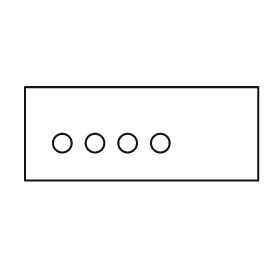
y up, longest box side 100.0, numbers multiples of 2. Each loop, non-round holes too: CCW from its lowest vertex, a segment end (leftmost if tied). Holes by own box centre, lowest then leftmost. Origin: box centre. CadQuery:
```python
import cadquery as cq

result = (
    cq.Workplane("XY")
    .moveTo(-50.0, -20.0)
    .lineTo(50.0, -20.0)
    .lineTo(50.0, 20.0)
    .lineTo(-50.0, 20.0)
    .close()
    .moveTo(-34.0, -4.0)
    .circle(4.0)
    .moveTo(-20.0, -4.0)
    .circle(4.0)
    .moveTo(-6.0, -4.0)
    .circle(4.0)
    .moveTo(8.0, -4.0)
    .circle(4.0)
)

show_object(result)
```